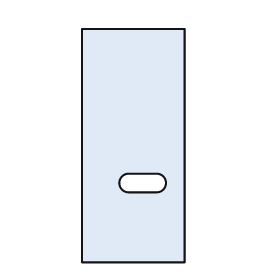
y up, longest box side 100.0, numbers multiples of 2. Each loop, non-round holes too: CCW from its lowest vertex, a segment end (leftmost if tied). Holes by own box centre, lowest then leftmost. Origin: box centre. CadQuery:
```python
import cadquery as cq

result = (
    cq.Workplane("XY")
    .moveTo(-22.0, -50.0)
    .lineTo(22.0, -50.0)
    .lineTo(22.0, 50.0)
    .lineTo(-22.0, 50.0)
    .close()
    .moveTo(-2.0, -20.0)
    .lineTo(10.0, -20.0)
    .threePointArc((14.0, -16.0), (10.0, -12.0))
    .lineTo(-2.0, -12.0)
    .threePointArc((-6.0, -16.0), (-2.0, -20.0))
    .close()
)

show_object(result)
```